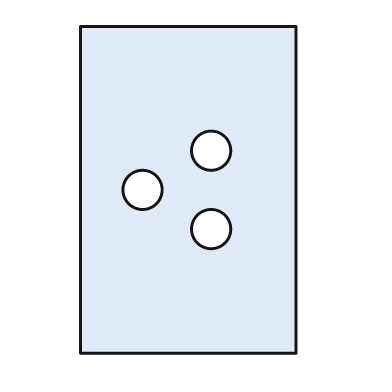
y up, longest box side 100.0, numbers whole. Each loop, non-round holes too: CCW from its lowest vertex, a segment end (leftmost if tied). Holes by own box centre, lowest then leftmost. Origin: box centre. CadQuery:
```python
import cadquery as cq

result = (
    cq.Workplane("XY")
    .moveTo(-33.0, -50.0)
    .lineTo(33.0, -50.0)
    .lineTo(33.0, 50.0)
    .lineTo(-33.0, 50.0)
    .close()
    .moveTo(7.0, -12.0)
    .circle(6.0)
    .moveTo(-14.0, 0.0)
    .circle(6.0)
    .moveTo(7.0, 12.0)
    .circle(6.0)
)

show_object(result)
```